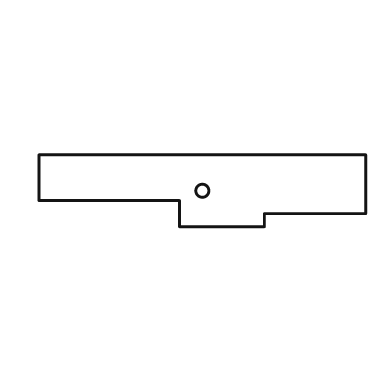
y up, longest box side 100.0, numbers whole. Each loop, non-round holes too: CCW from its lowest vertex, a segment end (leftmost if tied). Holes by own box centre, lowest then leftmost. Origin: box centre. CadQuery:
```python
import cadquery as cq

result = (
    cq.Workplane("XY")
    .moveTo(-7.0, -11.0)
    .lineTo(19.0, -11.0)
    .lineTo(19.0, -7.0)
    .lineTo(50.0, -7.0)
    .lineTo(50.0, 11.0)
    .lineTo(-50.0, 11.0)
    .lineTo(-50.0, -3.0)
    .lineTo(-7.0, -3.0)
    .close()
    .moveTo(0.0, 0.0)
    .circle(2.0)
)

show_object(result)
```